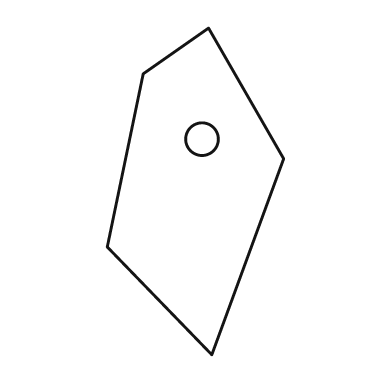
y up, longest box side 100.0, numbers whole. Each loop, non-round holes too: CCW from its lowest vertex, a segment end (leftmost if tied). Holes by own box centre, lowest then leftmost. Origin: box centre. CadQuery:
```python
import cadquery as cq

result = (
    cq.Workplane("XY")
    .moveTo(5.0, -50.0)
    .lineTo(27.0, 10.0)
    .lineTo(4.0, 50.0)
    .lineTo(-16.0, 36.0)
    .lineTo(-27.0, -17.0)
    .close()
    .moveTo(2.0, 16.0)
    .circle(5.0)
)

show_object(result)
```